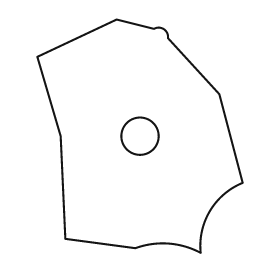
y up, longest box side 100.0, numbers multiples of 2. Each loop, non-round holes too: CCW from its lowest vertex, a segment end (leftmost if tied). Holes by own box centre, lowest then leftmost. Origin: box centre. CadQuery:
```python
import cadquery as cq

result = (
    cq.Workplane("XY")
    .moveTo(26.0, -50.0)
    .threePointArc((30.0, -32.0), (44.0, -20.0))
    .lineTo(34.0, 18.0)
    .lineTo(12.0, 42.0)
    .threePointArc((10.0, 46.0), (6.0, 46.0))
    .lineTo(-10.0, 50.0)
    .lineTo(-44.0, 34.0)
    .lineTo(-34.0, 0.0)
    .lineTo(-32.0, -44.0)
    .lineTo(-2.0, -48.0)
    .threePointArc((12.0, -46.0), (26.0, -50.0))
    .close()
    .moveTo(0.0, 0.0)
    .circle(8.0)
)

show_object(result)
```